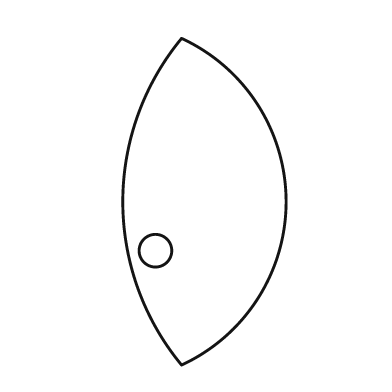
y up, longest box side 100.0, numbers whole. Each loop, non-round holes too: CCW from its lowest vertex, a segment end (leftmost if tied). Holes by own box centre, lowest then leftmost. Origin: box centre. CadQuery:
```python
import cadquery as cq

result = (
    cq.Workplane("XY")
    .moveTo(-7.0, -50.0)
    .threePointArc((25.0, 0.0), (-7.0, 50.0))
    .threePointArc((-25.0, 0.0), (-7.0, -50.0))
    .close()
    .moveTo(-15.0, -15.0)
    .circle(5.0)
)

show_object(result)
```